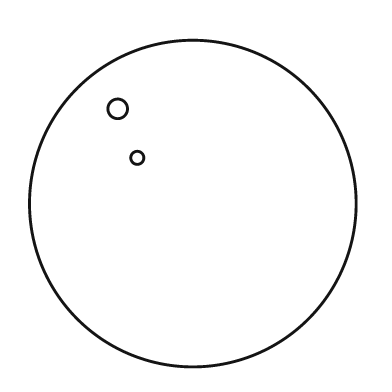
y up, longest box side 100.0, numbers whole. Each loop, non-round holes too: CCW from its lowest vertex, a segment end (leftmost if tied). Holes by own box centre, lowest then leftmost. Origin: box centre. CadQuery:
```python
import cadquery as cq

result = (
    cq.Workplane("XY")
    .moveTo(0.0, 0.0)
    .circle(50.0)
    .moveTo(-17.0, 14.0)
    .circle(2.0)
    .moveTo(-23.0, 29.0)
    .circle(3.0)
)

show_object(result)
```